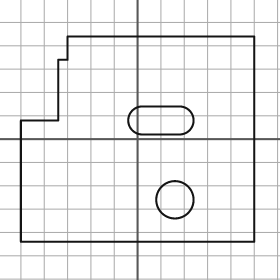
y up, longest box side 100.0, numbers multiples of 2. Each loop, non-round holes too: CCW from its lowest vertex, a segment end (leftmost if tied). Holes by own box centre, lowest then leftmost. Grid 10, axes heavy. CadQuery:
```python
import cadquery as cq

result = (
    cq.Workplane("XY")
    .moveTo(-50.0, -44.0)
    .lineTo(50.0, -44.0)
    .lineTo(50.0, 44.0)
    .lineTo(-30.0, 44.0)
    .lineTo(-30.0, 34.0)
    .lineTo(-34.0, 34.0)
    .lineTo(-34.0, 8.0)
    .lineTo(-50.0, 8.0)
    .close()
    .moveTo(16.0, -26.0)
    .circle(8.0)
    .moveTo(2.0, 2.0)
    .lineTo(18.0, 2.0)
    .threePointArc((24.0, 8.0), (18.0, 14.0))
    .lineTo(2.0, 14.0)
    .threePointArc((-4.0, 8.0), (2.0, 2.0))
    .close()
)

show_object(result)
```